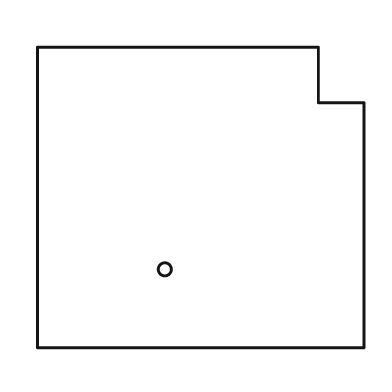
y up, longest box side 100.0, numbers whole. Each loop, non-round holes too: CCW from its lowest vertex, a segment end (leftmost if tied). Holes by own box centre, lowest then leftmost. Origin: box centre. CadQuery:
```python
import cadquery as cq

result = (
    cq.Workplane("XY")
    .moveTo(-50.0, -46.0)
    .lineTo(50.0, -46.0)
    .lineTo(50.0, 29.0)
    .lineTo(36.0, 29.0)
    .lineTo(36.0, 46.0)
    .lineTo(-50.0, 46.0)
    .close()
    .moveTo(-11.0, -22.0)
    .circle(2.0)
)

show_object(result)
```